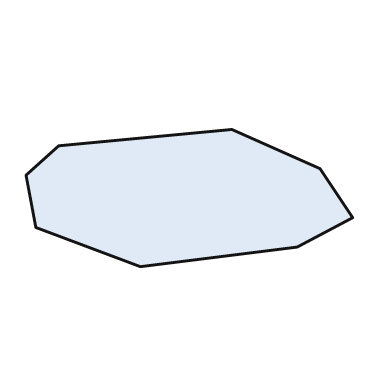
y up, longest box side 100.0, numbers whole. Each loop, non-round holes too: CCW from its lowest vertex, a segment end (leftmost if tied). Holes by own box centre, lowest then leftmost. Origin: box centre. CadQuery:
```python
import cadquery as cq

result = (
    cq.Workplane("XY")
    .moveTo(-15.0, -21.0)
    .lineTo(33.0, -15.0)
    .lineTo(50.0, -6.0)
    .lineTo(40.0, 9.0)
    .lineTo(13.0, 21.0)
    .lineTo(-40.0, 16.0)
    .lineTo(-50.0, 7.0)
    .lineTo(-47.0, -9.0)
    .close()
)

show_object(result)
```